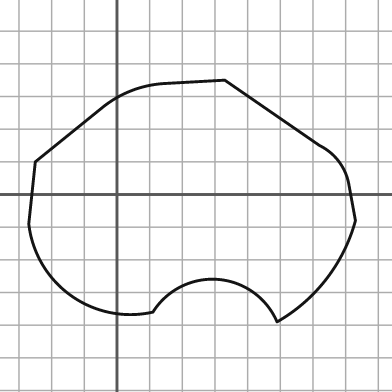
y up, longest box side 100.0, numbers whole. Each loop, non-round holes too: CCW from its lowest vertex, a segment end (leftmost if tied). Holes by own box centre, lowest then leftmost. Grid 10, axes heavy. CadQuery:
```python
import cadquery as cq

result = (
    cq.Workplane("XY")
    .moveTo(49.0, -39.0)
    .threePointArc((64.0, -26.0), (73.0, -8.0))
    .lineTo(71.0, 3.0)
    .threePointArc((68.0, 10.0), (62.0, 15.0))
    .lineTo(33.0, 35.0)
    .lineTo(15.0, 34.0)
    .threePointArc((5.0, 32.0), (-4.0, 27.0))
    .lineTo(-25.0, 10.0)
    .lineTo(-27.0, -9.0)
    .threePointArc((-14.0, -31.0), (11.0, -36.0))
    .threePointArc((31.0, -26.0), (49.0, -39.0))
    .close()
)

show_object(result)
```